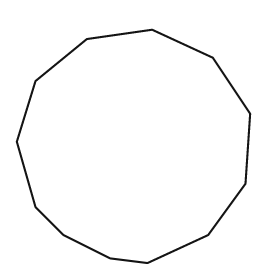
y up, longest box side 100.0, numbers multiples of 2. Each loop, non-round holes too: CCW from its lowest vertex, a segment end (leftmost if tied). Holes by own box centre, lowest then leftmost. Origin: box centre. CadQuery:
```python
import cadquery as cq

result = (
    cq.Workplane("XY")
    .moveTo(6.0, -50.0)
    .lineTo(32.0, -38.0)
    .lineTo(48.0, -16.0)
    .lineTo(50.0, 14.0)
    .lineTo(34.0, 38.0)
    .lineTo(8.0, 50.0)
    .lineTo(-20.0, 46.0)
    .lineTo(-42.0, 28.0)
    .lineTo(-50.0, 2.0)
    .lineTo(-42.0, -26.0)
    .lineTo(-30.0, -38.0)
    .lineTo(-10.0, -48.0)
    .close()
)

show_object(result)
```